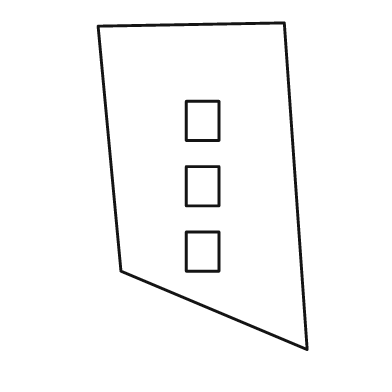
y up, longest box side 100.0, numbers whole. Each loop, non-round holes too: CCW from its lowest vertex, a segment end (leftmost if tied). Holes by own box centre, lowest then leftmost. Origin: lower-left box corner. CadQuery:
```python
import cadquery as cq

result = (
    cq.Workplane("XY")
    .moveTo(64.0, 0.0)
    .lineTo(57.0, 100.0)
    .lineTo(0.0, 99.0)
    .lineTo(7.0, 24.0)
    .close()
    .moveTo(27.0, 24.0)
    .lineTo(37.0, 24.0)
    .lineTo(37.0, 36.0)
    .lineTo(27.0, 36.0)
    .close()
    .moveTo(27.0, 44.0)
    .lineTo(37.0, 44.0)
    .lineTo(37.0, 56.0)
    .lineTo(27.0, 56.0)
    .close()
    .moveTo(27.0, 64.0)
    .lineTo(37.0, 64.0)
    .lineTo(37.0, 76.0)
    .lineTo(27.0, 76.0)
    .close()
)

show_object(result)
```